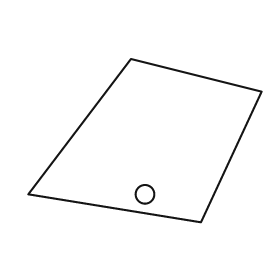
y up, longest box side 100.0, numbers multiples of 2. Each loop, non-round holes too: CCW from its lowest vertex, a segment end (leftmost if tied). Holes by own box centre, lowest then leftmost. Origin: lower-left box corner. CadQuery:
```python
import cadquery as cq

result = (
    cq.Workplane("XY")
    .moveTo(74.0, 0.0)
    .lineTo(100.0, 56.0)
    .lineTo(44.0, 70.0)
    .lineTo(0.0, 12.0)
    .close()
    .moveTo(50.0, 12.0)
    .circle(4.0)
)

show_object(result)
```